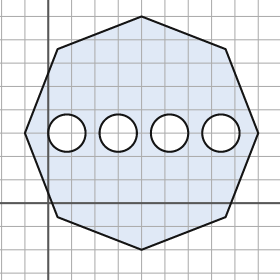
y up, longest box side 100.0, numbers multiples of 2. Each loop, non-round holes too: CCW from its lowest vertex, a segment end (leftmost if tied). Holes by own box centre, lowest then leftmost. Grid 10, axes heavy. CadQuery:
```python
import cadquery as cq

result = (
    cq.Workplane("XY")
    .moveTo(40.0, -20.0)
    .lineTo(76.0, -6.0)
    .lineTo(90.0, 30.0)
    .lineTo(76.0, 66.0)
    .lineTo(40.0, 80.0)
    .lineTo(4.0, 66.0)
    .lineTo(-10.0, 30.0)
    .lineTo(4.0, -6.0)
    .close()
    .moveTo(8.0, 30.0)
    .circle(8.0)
    .moveTo(30.0, 30.0)
    .circle(8.0)
    .moveTo(52.0, 30.0)
    .circle(8.0)
    .moveTo(74.0, 30.0)
    .circle(8.0)
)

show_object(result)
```